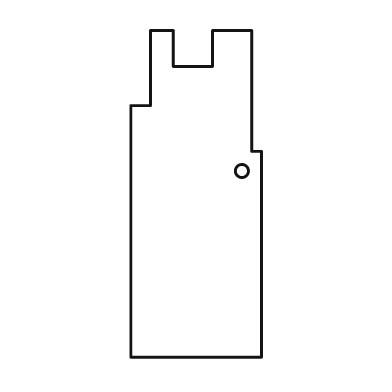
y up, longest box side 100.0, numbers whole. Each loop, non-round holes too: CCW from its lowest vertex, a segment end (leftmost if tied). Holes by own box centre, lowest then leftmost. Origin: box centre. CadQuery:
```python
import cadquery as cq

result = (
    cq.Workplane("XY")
    .moveTo(-20.0, -50.0)
    .lineTo(20.0, -50.0)
    .lineTo(20.0, 13.0)
    .lineTo(17.0, 13.0)
    .lineTo(17.0, 50.0)
    .lineTo(5.0, 50.0)
    .lineTo(5.0, 39.0)
    .lineTo(-7.0, 39.0)
    .lineTo(-7.0, 50.0)
    .lineTo(-14.0, 50.0)
    .lineTo(-14.0, 27.0)
    .lineTo(-20.0, 27.0)
    .close()
    .moveTo(14.0, 7.0)
    .circle(2.0)
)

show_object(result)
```